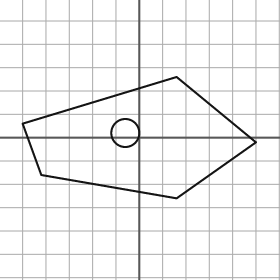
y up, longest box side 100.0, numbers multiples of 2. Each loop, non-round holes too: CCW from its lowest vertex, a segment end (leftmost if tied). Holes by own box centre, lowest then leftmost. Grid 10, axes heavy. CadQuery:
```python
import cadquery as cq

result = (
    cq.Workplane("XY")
    .moveTo(16.0, -26.0)
    .lineTo(50.0, -2.0)
    .lineTo(16.0, 26.0)
    .lineTo(-50.0, 6.0)
    .lineTo(-42.0, -16.0)
    .close()
    .moveTo(-6.0, 2.0)
    .circle(6.0)
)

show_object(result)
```